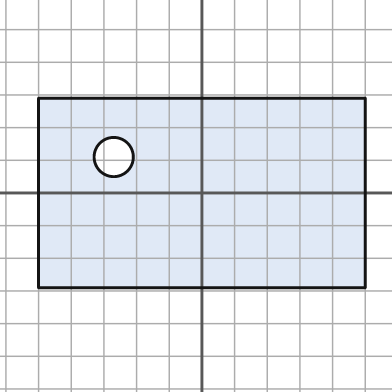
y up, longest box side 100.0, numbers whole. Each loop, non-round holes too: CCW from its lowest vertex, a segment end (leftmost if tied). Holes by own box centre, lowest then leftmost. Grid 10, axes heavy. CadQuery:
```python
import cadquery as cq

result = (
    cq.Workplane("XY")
    .moveTo(-50.0, -29.0)
    .lineTo(50.0, -29.0)
    .lineTo(50.0, 29.0)
    .lineTo(-50.0, 29.0)
    .close()
    .moveTo(-27.0, 11.0)
    .circle(6.0)
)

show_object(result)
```